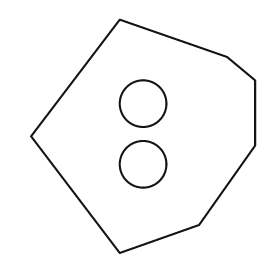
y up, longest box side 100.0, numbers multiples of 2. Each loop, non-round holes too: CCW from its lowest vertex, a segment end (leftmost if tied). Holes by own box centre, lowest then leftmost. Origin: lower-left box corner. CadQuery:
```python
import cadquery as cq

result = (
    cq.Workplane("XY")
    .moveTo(38.0, 0.0)
    .lineTo(72.0, 12.0)
    .lineTo(96.0, 46.0)
    .lineTo(96.0, 74.0)
    .lineTo(84.0, 84.0)
    .lineTo(38.0, 100.0)
    .lineTo(0.0, 50.0)
    .close()
    .moveTo(48.0, 38.0)
    .circle(10.0)
    .moveTo(48.0, 64.0)
    .circle(10.0)
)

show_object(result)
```